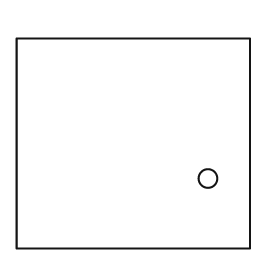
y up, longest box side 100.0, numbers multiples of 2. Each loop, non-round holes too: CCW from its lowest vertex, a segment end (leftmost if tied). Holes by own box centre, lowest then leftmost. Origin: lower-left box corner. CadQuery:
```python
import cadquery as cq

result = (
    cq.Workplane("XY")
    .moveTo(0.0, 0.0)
    .lineTo(100.0, 0.0)
    .lineTo(100.0, 90.0)
    .lineTo(0.0, 90.0)
    .close()
    .moveTo(82.0, 30.0)
    .circle(4.0)
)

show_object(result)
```